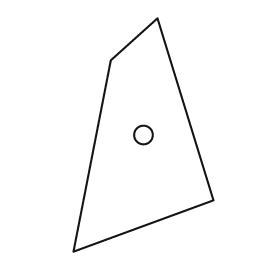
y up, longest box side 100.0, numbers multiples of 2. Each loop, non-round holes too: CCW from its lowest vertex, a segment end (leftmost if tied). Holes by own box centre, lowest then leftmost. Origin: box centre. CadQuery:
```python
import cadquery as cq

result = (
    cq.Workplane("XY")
    .moveTo(-30.0, -50.0)
    .lineTo(30.0, -28.0)
    .lineTo(6.0, 50.0)
    .lineTo(-14.0, 32.0)
    .close()
    .moveTo(0.0, 0.0)
    .circle(4.0)
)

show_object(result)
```